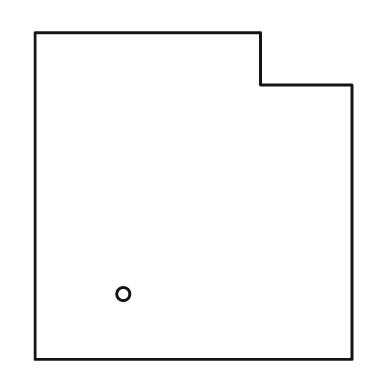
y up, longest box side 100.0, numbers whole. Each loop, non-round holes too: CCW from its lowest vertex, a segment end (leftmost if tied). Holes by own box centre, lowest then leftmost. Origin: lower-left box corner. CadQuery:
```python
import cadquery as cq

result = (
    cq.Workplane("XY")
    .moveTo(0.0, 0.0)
    .lineTo(97.0, 0.0)
    .lineTo(97.0, 84.0)
    .lineTo(69.0, 84.0)
    .lineTo(69.0, 100.0)
    .lineTo(0.0, 100.0)
    .close()
    .moveTo(27.0, 20.0)
    .circle(2.0)
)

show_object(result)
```